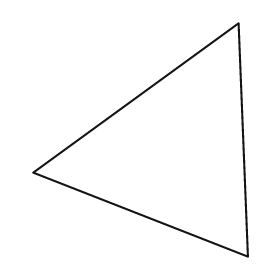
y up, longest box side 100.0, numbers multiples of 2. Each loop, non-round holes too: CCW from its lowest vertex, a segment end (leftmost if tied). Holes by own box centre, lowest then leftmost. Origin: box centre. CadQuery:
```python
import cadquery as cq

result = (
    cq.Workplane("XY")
    .moveTo(46.0, -50.0)
    .lineTo(42.0, 50.0)
    .lineTo(-46.0, -14.0)
    .close()
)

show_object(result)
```